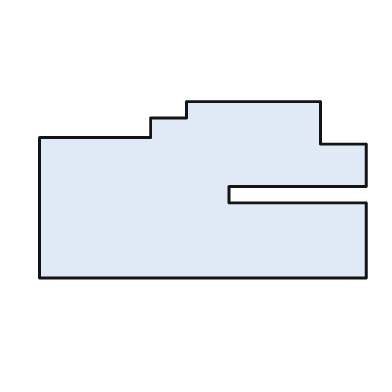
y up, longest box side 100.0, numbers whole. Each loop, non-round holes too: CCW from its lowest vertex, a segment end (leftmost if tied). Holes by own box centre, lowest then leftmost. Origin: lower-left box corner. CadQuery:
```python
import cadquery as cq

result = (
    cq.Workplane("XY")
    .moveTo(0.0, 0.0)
    .lineTo(100.0, 0.0)
    .lineTo(100.0, 23.0)
    .lineTo(58.0, 23.0)
    .lineTo(58.0, 28.0)
    .lineTo(100.0, 28.0)
    .lineTo(100.0, 41.0)
    .lineTo(86.0, 41.0)
    .lineTo(86.0, 54.0)
    .lineTo(45.0, 54.0)
    .lineTo(45.0, 49.0)
    .lineTo(34.0, 49.0)
    .lineTo(34.0, 43.0)
    .lineTo(0.0, 43.0)
    .close()
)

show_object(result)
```